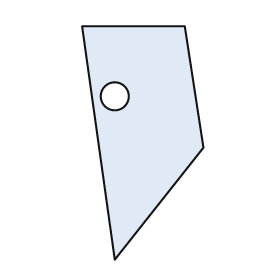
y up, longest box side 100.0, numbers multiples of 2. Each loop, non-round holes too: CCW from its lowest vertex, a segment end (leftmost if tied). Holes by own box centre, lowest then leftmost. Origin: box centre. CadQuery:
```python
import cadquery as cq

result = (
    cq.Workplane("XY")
    .moveTo(-12.0, -50.0)
    .lineTo(26.0, -2.0)
    .lineTo(18.0, 50.0)
    .lineTo(-26.0, 50.0)
    .close()
    .moveTo(-12.0, 20.0)
    .circle(6.0)
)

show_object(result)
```